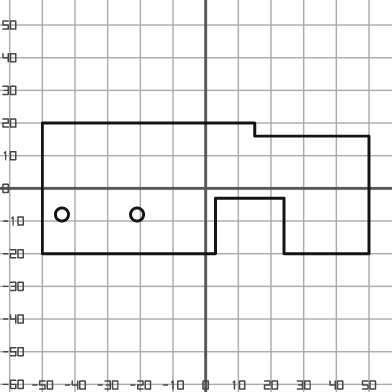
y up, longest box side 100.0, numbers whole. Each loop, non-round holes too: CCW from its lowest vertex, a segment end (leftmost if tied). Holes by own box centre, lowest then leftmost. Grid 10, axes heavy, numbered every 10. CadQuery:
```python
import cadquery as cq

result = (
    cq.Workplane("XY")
    .moveTo(-50.0, -20.0)
    .lineTo(3.0, -20.0)
    .lineTo(3.0, -3.0)
    .lineTo(24.0, -3.0)
    .lineTo(24.0, -20.0)
    .lineTo(50.0, -20.0)
    .lineTo(50.0, 16.0)
    .lineTo(15.0, 16.0)
    .lineTo(15.0, 20.0)
    .lineTo(-50.0, 20.0)
    .close()
    .moveTo(-44.0, -8.0)
    .circle(2.0)
    .moveTo(-21.0, -8.0)
    .circle(2.0)
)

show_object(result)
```